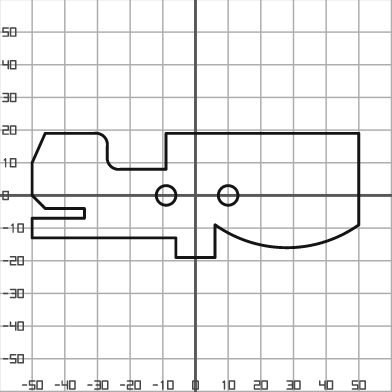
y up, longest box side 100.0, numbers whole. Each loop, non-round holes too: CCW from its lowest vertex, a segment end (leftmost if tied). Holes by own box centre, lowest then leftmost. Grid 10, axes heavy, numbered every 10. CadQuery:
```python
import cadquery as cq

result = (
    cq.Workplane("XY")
    .moveTo(-6.0, -19.0)
    .lineTo(6.0, -19.0)
    .lineTo(6.0, -9.0)
    .threePointArc((28.0, -16.0), (50.0, -9.0))
    .lineTo(50.0, 19.0)
    .lineTo(-9.0, 19.0)
    .lineTo(-9.0, 8.0)
    .lineTo(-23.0, 8.0)
    .threePointArc((-26.0, 9.0), (-27.0, 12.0))
    .lineTo(-27.0, 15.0)
    .threePointArc((-28.0, 18.0), (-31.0, 19.0))
    .lineTo(-46.0, 19.0)
    .lineTo(-50.0, 10.0)
    .lineTo(-50.0, 0.0)
    .lineTo(-46.0, -4.0)
    .lineTo(-34.0, -4.0)
    .lineTo(-34.0, -7.0)
    .lineTo(-50.0, -7.0)
    .lineTo(-50.0, -13.0)
    .lineTo(-6.0, -13.0)
    .close()
    .moveTo(-9.0, 0.0)
    .circle(3.0)
    .moveTo(10.0, 0.0)
    .circle(3.0)
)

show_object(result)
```